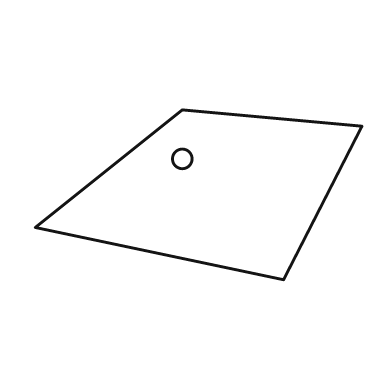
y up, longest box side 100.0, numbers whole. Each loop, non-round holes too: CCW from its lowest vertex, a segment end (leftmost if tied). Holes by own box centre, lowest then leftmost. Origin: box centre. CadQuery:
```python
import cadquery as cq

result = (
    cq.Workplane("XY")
    .moveTo(26.0, -26.0)
    .lineTo(50.0, 21.0)
    .lineTo(-5.0, 26.0)
    .lineTo(-50.0, -10.0)
    .close()
    .moveTo(-5.0, 11.0)
    .circle(3.0)
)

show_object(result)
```